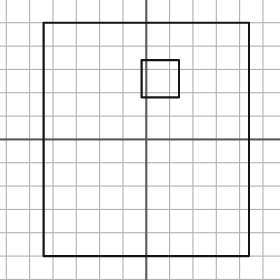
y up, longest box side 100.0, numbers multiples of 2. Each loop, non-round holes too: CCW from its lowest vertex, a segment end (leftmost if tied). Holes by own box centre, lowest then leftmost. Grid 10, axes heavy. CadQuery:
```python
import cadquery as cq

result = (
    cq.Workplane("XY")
    .moveTo(-44.0, -50.0)
    .lineTo(44.0, -50.0)
    .lineTo(44.0, 50.0)
    .lineTo(-44.0, 50.0)
    .close()
    .moveTo(-2.0, 18.0)
    .lineTo(14.0, 18.0)
    .lineTo(14.0, 34.0)
    .lineTo(-2.0, 34.0)
    .close()
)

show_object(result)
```